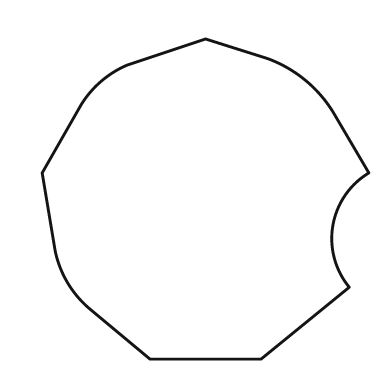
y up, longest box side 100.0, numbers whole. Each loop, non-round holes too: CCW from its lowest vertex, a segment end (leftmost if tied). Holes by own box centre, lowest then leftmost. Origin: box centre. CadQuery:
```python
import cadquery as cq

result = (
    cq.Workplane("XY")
    .moveTo(-17.0, -49.0)
    .lineTo(17.0, -49.0)
    .lineTo(44.0, -27.0)
    .threePointArc((39.0, -8.0), (50.0, 8.0))
    .lineTo(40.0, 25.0)
    .threePointArc((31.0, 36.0), (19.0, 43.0))
    .lineTo(0.0, 49.0)
    .lineTo(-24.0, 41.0)
    .threePointArc((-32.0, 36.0), (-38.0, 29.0))
    .lineTo(-50.0, 8.0)
    .lineTo(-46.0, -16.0)
    .threePointArc((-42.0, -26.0), (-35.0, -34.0))
    .close()
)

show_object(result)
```